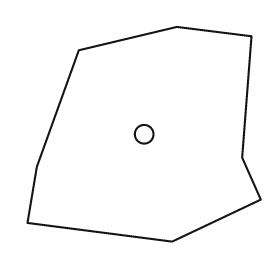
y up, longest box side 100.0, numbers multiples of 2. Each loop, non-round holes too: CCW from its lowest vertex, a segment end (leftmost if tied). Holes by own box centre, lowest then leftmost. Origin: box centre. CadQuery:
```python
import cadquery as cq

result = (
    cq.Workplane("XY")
    .moveTo(12.0, -46.0)
    .lineTo(50.0, -28.0)
    .lineTo(42.0, -10.0)
    .lineTo(46.0, 42.0)
    .lineTo(14.0, 46.0)
    .lineTo(-28.0, 36.0)
    .lineTo(-46.0, -14.0)
    .lineTo(-50.0, -38.0)
    .close()
    .moveTo(0.0, 0.0)
    .circle(4.0)
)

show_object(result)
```